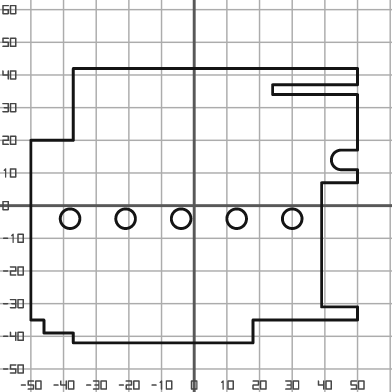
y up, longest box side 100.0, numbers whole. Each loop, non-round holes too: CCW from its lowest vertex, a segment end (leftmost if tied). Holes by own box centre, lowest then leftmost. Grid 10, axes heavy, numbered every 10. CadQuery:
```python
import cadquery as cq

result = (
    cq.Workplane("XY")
    .moveTo(-37.0, -42.0)
    .lineTo(18.0, -42.0)
    .lineTo(18.0, -35.0)
    .lineTo(50.0, -35.0)
    .lineTo(50.0, -31.0)
    .lineTo(39.0, -31.0)
    .lineTo(39.0, 7.0)
    .lineTo(50.0, 7.0)
    .lineTo(50.0, 11.0)
    .lineTo(45.0, 11.0)
    .threePointArc((42.0, 14.0), (45.0, 17.0))
    .lineTo(50.0, 17.0)
    .lineTo(50.0, 34.0)
    .lineTo(24.0, 34.0)
    .lineTo(24.0, 37.0)
    .lineTo(50.0, 37.0)
    .lineTo(50.0, 42.0)
    .lineTo(-37.0, 42.0)
    .lineTo(-37.0, 20.0)
    .lineTo(-50.0, 20.0)
    .lineTo(-50.0, -35.0)
    .lineTo(-46.0, -35.0)
    .lineTo(-46.0, -39.0)
    .lineTo(-37.0, -39.0)
    .close()
    .moveTo(-38.0, -4.0)
    .circle(3.0)
    .moveTo(-21.0, -4.0)
    .circle(3.0)
    .moveTo(-4.0, -4.0)
    .circle(3.0)
    .moveTo(13.0, -4.0)
    .circle(3.0)
    .moveTo(30.0, -4.0)
    .circle(3.0)
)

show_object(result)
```